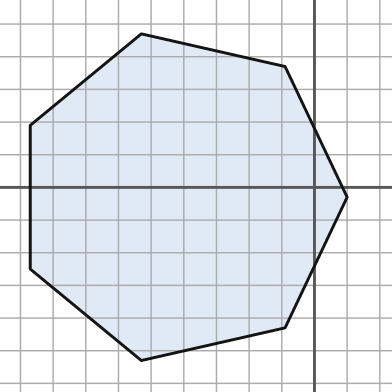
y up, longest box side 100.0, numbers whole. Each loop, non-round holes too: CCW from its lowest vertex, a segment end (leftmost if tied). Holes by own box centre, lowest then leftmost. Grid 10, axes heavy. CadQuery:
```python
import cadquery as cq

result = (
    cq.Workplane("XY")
    .moveTo(-53.0, -53.0)
    .lineTo(-9.0, -43.0)
    .lineTo(10.0, -3.0)
    .lineTo(-9.0, 37.0)
    .lineTo(-53.0, 47.0)
    .lineTo(-87.0, 19.0)
    .lineTo(-87.0, -25.0)
    .close()
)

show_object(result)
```